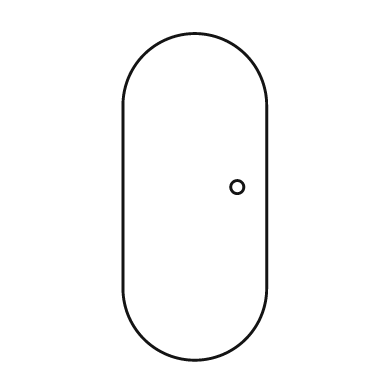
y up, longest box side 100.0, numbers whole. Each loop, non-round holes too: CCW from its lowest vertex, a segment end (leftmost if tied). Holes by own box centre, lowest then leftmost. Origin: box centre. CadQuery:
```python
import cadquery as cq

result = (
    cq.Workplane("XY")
    .moveTo(-22.0, -28.0)
    .threePointArc((0.0, -50.0), (22.0, -28.0))
    .lineTo(22.0, 28.0)
    .threePointArc((0.0, 50.0), (-22.0, 28.0))
    .close()
    .moveTo(13.0, 3.0)
    .circle(2.0)
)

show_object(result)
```